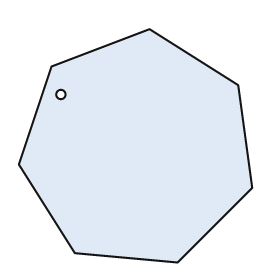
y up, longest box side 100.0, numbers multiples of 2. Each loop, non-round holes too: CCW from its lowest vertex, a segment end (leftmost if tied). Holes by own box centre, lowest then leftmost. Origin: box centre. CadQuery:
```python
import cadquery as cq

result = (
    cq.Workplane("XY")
    .moveTo(18.0, -50.0)
    .lineTo(50.0, -18.0)
    .lineTo(44.0, 26.0)
    .lineTo(6.0, 50.0)
    .lineTo(-36.0, 34.0)
    .lineTo(-50.0, -8.0)
    .lineTo(-26.0, -46.0)
    .close()
    .moveTo(-32.0, 22.0)
    .circle(2.0)
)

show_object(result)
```